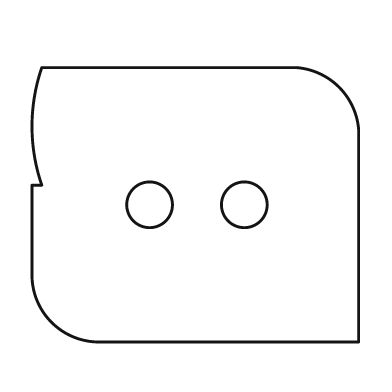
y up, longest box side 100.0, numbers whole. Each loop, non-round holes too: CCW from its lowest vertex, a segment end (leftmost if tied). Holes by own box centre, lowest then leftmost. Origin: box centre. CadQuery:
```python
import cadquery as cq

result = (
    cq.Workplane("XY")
    .moveTo(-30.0, -42.0)
    .lineTo(50.0, -42.0)
    .lineTo(50.0, 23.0)
    .threePointArc((44.0, 36.0), (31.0, 42.0))
    .lineTo(-47.0, 42.0)
    .threePointArc((-50.0, 24.0), (-47.0, 6.0))
    .lineTo(-50.0, 6.0)
    .lineTo(-50.0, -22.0)
    .threePointArc((-44.0, -36.0), (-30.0, -42.0))
    .close()
    .moveTo(-14.0, 0.0)
    .circle(7.0)
    .moveTo(15.0, 0.0)
    .circle(7.0)
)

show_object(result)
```